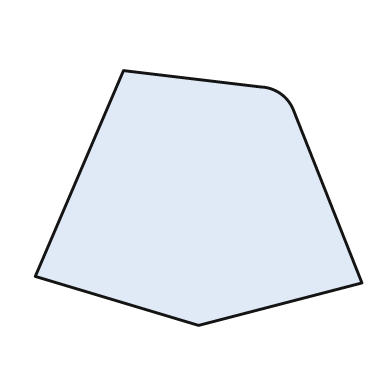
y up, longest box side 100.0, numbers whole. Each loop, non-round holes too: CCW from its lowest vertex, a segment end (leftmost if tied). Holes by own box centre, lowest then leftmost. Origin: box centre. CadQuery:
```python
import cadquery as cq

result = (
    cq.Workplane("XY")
    .moveTo(0.0, -39.0)
    .lineTo(50.0, -26.0)
    .lineTo(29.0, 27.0)
    .threePointArc((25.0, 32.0), (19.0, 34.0))
    .lineTo(-23.0, 39.0)
    .lineTo(-50.0, -24.0)
    .close()
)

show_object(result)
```